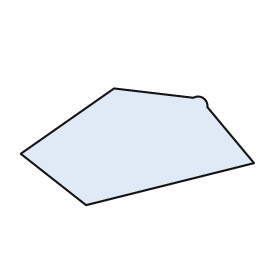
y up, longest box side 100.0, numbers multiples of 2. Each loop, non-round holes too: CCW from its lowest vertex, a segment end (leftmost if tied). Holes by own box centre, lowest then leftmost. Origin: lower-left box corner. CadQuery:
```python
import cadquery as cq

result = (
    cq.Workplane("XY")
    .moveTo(28.0, 0.0)
    .lineTo(100.0, 18.0)
    .lineTo(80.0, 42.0)
    .threePointArc((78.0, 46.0), (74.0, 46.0))
    .lineTo(40.0, 50.0)
    .lineTo(0.0, 22.0)
    .close()
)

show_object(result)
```